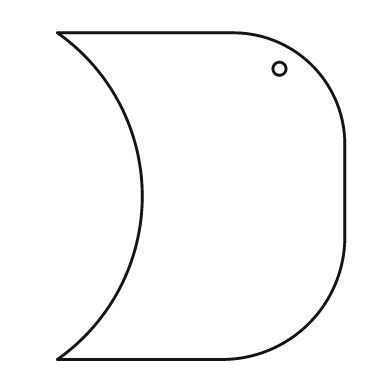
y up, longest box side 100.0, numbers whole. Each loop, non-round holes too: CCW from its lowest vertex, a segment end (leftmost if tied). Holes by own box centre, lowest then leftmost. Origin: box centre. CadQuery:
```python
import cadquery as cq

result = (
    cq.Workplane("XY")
    .moveTo(-44.0, -50.0)
    .lineTo(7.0, -50.0)
    .threePointArc((33.0, -39.0), (44.0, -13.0))
    .lineTo(44.0, 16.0)
    .threePointArc((34.0, 40.0), (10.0, 50.0))
    .lineTo(-44.0, 50.0)
    .threePointArc((-18.0, 0.0), (-44.0, -50.0))
    .close()
    .moveTo(24.0, 39.0)
    .circle(2.0)
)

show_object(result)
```